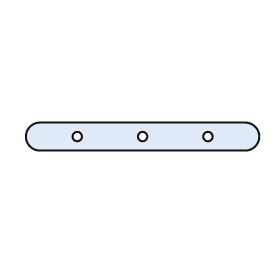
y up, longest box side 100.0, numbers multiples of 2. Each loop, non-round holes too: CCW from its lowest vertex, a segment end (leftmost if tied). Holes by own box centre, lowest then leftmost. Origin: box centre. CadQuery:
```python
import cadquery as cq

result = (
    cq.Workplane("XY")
    .moveTo(-44.0, -6.0)
    .lineTo(44.0, -6.0)
    .threePointArc((50.0, 0.0), (44.0, 6.0))
    .lineTo(-44.0, 6.0)
    .threePointArc((-50.0, 0.0), (-44.0, -6.0))
    .close()
    .moveTo(-28.0, 0.0)
    .circle(2.0)
    .moveTo(0.0, 0.0)
    .circle(2.0)
    .moveTo(28.0, 0.0)
    .circle(2.0)
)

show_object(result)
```